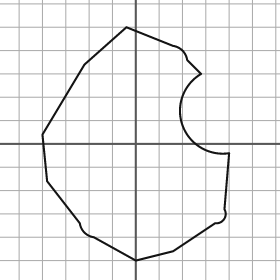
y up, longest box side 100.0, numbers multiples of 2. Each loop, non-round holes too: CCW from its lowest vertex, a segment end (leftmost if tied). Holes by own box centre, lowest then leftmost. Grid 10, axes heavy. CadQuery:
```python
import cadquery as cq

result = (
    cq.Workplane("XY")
    .moveTo(0.0, -50.0)
    .lineTo(16.0, -46.0)
    .lineTo(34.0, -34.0)
    .threePointArc((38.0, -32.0), (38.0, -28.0))
    .lineTo(40.0, -4.0)
    .threePointArc((20.0, 8.0), (28.0, 30.0))
    .lineTo(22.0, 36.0)
    .threePointArc((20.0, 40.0), (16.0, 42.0))
    .lineTo(-4.0, 50.0)
    .lineTo(-22.0, 34.0)
    .lineTo(-40.0, 4.0)
    .lineTo(-38.0, -16.0)
    .lineTo(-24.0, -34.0)
    .threePointArc((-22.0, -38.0), (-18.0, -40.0))
    .close()
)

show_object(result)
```